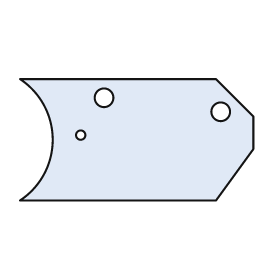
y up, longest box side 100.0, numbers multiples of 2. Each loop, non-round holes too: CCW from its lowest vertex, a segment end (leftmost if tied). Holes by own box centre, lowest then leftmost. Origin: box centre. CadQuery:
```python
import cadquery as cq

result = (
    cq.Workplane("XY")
    .moveTo(-50.0, -26.0)
    .lineTo(34.0, -26.0)
    .lineTo(50.0, -4.0)
    .lineTo(50.0, 10.0)
    .lineTo(34.0, 26.0)
    .lineTo(-50.0, 26.0)
    .threePointArc((-36.0, 0.0), (-50.0, -26.0))
    .close()
    .moveTo(-24.0, 2.0)
    .circle(2.0)
    .moveTo(36.0, 12.0)
    .circle(4.0)
    .moveTo(-14.0, 18.0)
    .circle(4.0)
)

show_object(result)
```